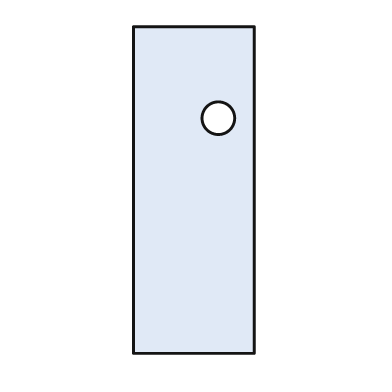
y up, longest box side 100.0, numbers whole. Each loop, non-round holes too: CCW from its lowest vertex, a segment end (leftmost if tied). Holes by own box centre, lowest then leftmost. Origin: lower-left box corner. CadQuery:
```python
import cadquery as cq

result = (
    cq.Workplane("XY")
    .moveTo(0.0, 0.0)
    .lineTo(37.0, 0.0)
    .lineTo(37.0, 100.0)
    .lineTo(0.0, 100.0)
    .close()
    .moveTo(26.0, 72.0)
    .circle(5.0)
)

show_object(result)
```